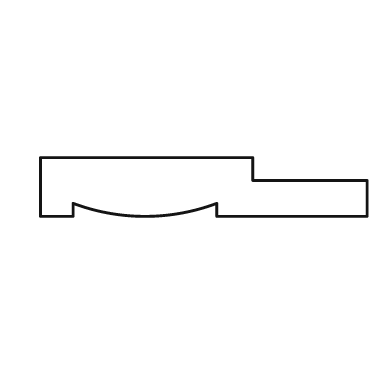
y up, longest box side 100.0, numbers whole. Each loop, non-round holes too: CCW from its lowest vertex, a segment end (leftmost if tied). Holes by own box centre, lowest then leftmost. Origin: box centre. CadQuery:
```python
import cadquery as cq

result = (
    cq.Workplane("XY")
    .moveTo(-50.0, -9.0)
    .lineTo(-40.0, -9.0)
    .lineTo(-40.0, -5.0)
    .threePointArc((-18.0, -9.0), (4.0, -5.0))
    .lineTo(4.0, -9.0)
    .lineTo(50.0, -9.0)
    .lineTo(50.0, 2.0)
    .lineTo(15.0, 2.0)
    .lineTo(15.0, 9.0)
    .lineTo(-50.0, 9.0)
    .close()
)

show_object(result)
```